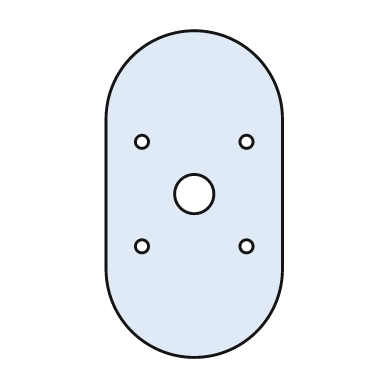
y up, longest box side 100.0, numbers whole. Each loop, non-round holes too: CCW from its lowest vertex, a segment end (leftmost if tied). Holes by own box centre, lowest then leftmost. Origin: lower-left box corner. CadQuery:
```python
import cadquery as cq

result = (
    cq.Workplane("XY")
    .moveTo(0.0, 27.0)
    .threePointArc((27.0, 0.0), (54.0, 27.0))
    .lineTo(54.0, 73.0)
    .threePointArc((27.0, 100.0), (0.0, 73.0))
    .close()
    .moveTo(11.0, 34.0)
    .circle(2.0)
    .moveTo(43.0, 34.0)
    .circle(2.0)
    .moveTo(27.0, 50.0)
    .circle(6.0)
    .moveTo(11.0, 66.0)
    .circle(2.0)
    .moveTo(43.0, 66.0)
    .circle(2.0)
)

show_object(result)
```